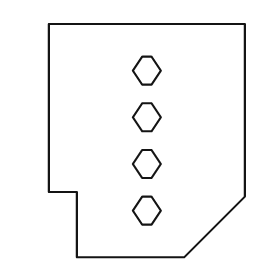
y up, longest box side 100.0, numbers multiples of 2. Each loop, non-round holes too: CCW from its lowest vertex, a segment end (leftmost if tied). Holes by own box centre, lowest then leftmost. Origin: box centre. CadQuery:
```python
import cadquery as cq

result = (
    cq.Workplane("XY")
    .moveTo(-30.0, -50.0)
    .lineTo(16.0, -50.0)
    .lineTo(42.0, -24.0)
    .lineTo(42.0, 50.0)
    .lineTo(-42.0, 50.0)
    .lineTo(-42.0, -22.0)
    .lineTo(-30.0, -22.0)
    .close()
    .moveTo(-2.0, -36.0)
    .lineTo(2.0, -36.0)
    .lineTo(6.0, -30.0)
    .lineTo(2.0, -24.0)
    .lineTo(-2.0, -24.0)
    .lineTo(-6.0, -30.0)
    .close()
    .moveTo(-2.0, -16.0)
    .lineTo(2.0, -16.0)
    .lineTo(6.0, -10.0)
    .lineTo(2.0, -4.0)
    .lineTo(-2.0, -4.0)
    .lineTo(-6.0, -10.0)
    .close()
    .moveTo(-2.0, 4.0)
    .lineTo(2.0, 4.0)
    .lineTo(6.0, 10.0)
    .lineTo(2.0, 16.0)
    .lineTo(-2.0, 16.0)
    .lineTo(-6.0, 10.0)
    .close()
    .moveTo(-2.0, 24.0)
    .lineTo(2.0, 24.0)
    .lineTo(6.0, 30.0)
    .lineTo(2.0, 36.0)
    .lineTo(-2.0, 36.0)
    .lineTo(-6.0, 30.0)
    .close()
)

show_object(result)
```